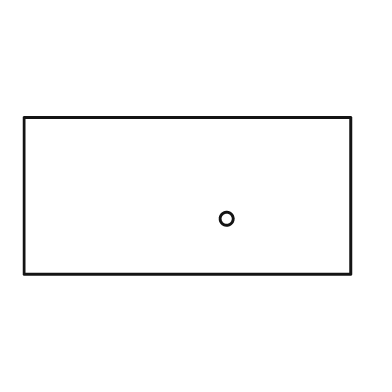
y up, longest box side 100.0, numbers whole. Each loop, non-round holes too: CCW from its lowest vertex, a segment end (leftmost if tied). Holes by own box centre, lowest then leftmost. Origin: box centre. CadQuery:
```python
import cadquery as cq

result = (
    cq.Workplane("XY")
    .moveTo(-50.0, -24.0)
    .lineTo(50.0, -24.0)
    .lineTo(50.0, 24.0)
    .lineTo(-50.0, 24.0)
    .close()
    .moveTo(12.0, -7.0)
    .circle(2.0)
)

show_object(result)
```